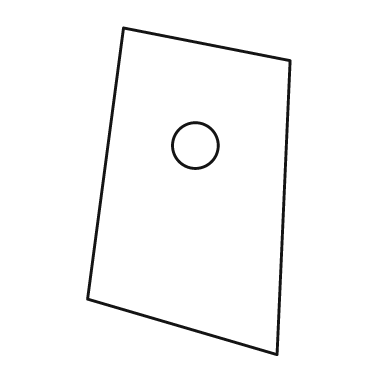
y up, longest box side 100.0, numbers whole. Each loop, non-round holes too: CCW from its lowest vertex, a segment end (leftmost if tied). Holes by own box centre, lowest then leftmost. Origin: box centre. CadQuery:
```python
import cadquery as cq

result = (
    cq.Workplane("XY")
    .moveTo(27.0, -50.0)
    .lineTo(31.0, 40.0)
    .lineTo(-20.0, 50.0)
    .lineTo(-31.0, -33.0)
    .close()
    .moveTo(2.0, 14.0)
    .circle(7.0)
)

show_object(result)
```